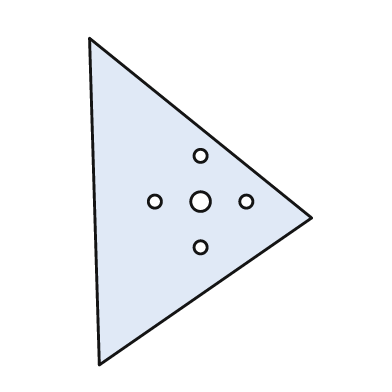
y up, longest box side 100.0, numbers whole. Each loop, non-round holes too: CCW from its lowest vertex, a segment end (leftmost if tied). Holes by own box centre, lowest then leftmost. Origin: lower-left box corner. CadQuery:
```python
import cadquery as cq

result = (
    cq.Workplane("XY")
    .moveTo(3.0, 0.0)
    .lineTo(68.0, 45.0)
    .lineTo(0.0, 100.0)
    .close()
    .moveTo(34.0, 36.0)
    .circle(2.0)
    .moveTo(20.0, 50.0)
    .circle(2.0)
    .moveTo(34.0, 50.0)
    .circle(3.0)
    .moveTo(48.0, 50.0)
    .circle(2.0)
    .moveTo(34.0, 64.0)
    .circle(2.0)
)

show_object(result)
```